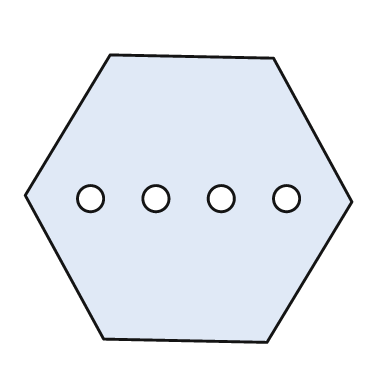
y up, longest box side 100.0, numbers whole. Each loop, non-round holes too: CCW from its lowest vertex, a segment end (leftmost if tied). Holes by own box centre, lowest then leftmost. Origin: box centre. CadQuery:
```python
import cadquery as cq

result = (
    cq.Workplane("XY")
    .moveTo(24.0, -44.0)
    .lineTo(50.0, -1.0)
    .lineTo(26.0, 43.0)
    .lineTo(-24.0, 44.0)
    .lineTo(-50.0, 1.0)
    .lineTo(-26.0, -43.0)
    .close()
    .moveTo(-30.0, 0.0)
    .circle(4.0)
    .moveTo(-10.0, 0.0)
    .circle(4.0)
    .moveTo(10.0, 0.0)
    .circle(4.0)
    .moveTo(30.0, 0.0)
    .circle(4.0)
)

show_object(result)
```